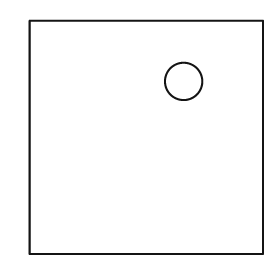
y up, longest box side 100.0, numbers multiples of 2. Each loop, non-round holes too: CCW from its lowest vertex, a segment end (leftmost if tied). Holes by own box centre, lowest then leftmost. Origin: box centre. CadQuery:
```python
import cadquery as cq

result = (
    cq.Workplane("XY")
    .moveTo(-50.0, -50.0)
    .lineTo(50.0, -50.0)
    .lineTo(50.0, 50.0)
    .lineTo(-50.0, 50.0)
    .close()
    .moveTo(16.0, 24.0)
    .circle(8.0)
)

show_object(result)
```